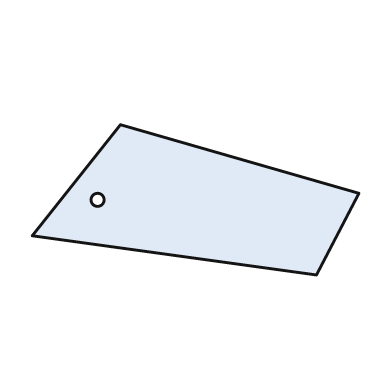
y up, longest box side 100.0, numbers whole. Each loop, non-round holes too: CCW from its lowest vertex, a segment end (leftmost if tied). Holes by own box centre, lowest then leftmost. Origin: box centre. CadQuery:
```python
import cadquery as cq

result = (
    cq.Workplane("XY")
    .moveTo(37.0, -23.0)
    .lineTo(50.0, 2.0)
    .lineTo(-23.0, 23.0)
    .lineTo(-50.0, -11.0)
    .close()
    .moveTo(-30.0, 0.0)
    .circle(2.0)
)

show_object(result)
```